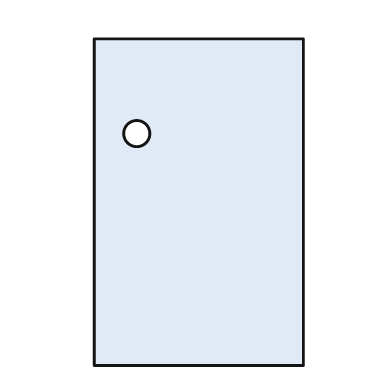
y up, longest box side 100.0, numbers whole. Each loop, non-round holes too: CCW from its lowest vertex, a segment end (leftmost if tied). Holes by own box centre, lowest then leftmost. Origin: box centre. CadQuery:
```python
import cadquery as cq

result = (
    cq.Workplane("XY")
    .moveTo(-32.0, -50.0)
    .lineTo(32.0, -50.0)
    .lineTo(32.0, 50.0)
    .lineTo(-32.0, 50.0)
    .close()
    .moveTo(-19.0, 21.0)
    .circle(4.0)
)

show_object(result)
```